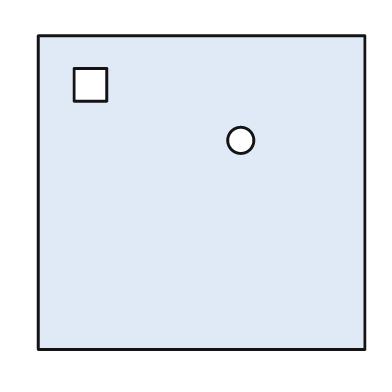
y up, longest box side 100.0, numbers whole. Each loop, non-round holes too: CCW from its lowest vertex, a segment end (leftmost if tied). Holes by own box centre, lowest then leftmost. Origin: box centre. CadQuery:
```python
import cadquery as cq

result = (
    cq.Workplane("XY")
    .moveTo(-50.0, -48.0)
    .lineTo(50.0, -48.0)
    .lineTo(50.0, 48.0)
    .lineTo(-50.0, 48.0)
    .close()
    .moveTo(12.0, 16.0)
    .circle(4.0)
    .moveTo(-39.0, 28.0)
    .lineTo(-29.0, 28.0)
    .lineTo(-29.0, 38.0)
    .lineTo(-39.0, 38.0)
    .close()
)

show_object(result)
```